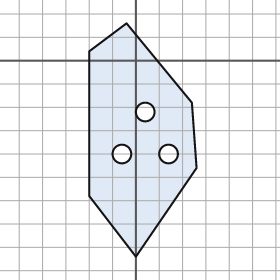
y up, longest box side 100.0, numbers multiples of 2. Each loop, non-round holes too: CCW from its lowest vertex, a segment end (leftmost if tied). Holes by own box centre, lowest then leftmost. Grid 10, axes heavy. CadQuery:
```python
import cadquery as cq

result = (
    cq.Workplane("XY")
    .moveTo(0.0, -84.0)
    .lineTo(26.0, -46.0)
    .lineTo(24.0, -18.0)
    .lineTo(-4.0, 16.0)
    .lineTo(-20.0, 4.0)
    .lineTo(-20.0, -58.0)
    .close()
    .moveTo(-6.0, -40.0)
    .circle(4.0)
    .moveTo(14.0, -40.0)
    .circle(4.0)
    .moveTo(4.0, -22.0)
    .circle(4.0)
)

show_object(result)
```